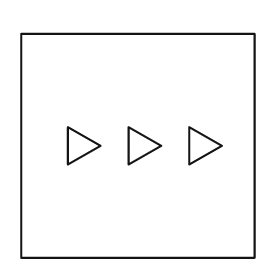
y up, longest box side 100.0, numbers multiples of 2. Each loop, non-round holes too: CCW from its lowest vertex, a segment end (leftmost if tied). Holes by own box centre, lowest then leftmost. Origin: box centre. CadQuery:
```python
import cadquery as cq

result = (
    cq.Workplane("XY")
    .moveTo(-50.0, -48.0)
    .lineTo(50.0, -48.0)
    .lineTo(50.0, 48.0)
    .lineTo(-50.0, 48.0)
    .close()
    .moveTo(-30.0, -8.0)
    .lineTo(-16.0, 0.0)
    .lineTo(-30.0, 8.0)
    .close()
    .moveTo(-4.0, -8.0)
    .lineTo(10.0, 0.0)
    .lineTo(-4.0, 8.0)
    .close()
    .moveTo(22.0, -8.0)
    .lineTo(36.0, 0.0)
    .lineTo(22.0, 8.0)
    .close()
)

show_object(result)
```